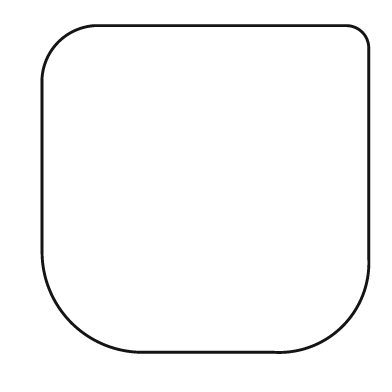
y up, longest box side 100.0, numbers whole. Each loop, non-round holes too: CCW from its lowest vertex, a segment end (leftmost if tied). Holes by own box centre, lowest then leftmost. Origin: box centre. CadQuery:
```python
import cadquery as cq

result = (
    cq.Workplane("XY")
    .moveTo(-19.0, -50.0)
    .lineTo(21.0, -50.0)
    .threePointArc((42.0, -42.0), (50.0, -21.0))
    .lineTo(50.0, 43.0)
    .threePointArc((48.0, 48.0), (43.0, 50.0))
    .lineTo(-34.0, 50.0)
    .threePointArc((-45.0, 45.0), (-50.0, 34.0))
    .lineTo(-50.0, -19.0)
    .threePointArc((-41.0, -41.0), (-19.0, -50.0))
    .close()
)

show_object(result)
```